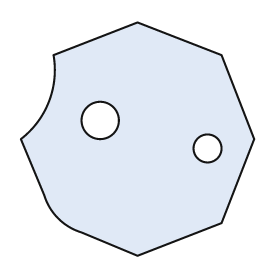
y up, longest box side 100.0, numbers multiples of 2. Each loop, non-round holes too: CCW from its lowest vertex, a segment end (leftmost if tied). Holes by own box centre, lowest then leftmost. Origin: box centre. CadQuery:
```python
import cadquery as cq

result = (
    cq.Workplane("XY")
    .moveTo(0.0, -50.0)
    .lineTo(36.0, -36.0)
    .lineTo(50.0, 0.0)
    .lineTo(36.0, 36.0)
    .lineTo(0.0, 50.0)
    .lineTo(-36.0, 36.0)
    .threePointArc((-38.0, 16.0), (-50.0, 0.0))
    .lineTo(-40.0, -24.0)
    .threePointArc((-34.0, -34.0), (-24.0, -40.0))
    .close()
    .moveTo(30.0, -4.0)
    .circle(6.0)
    .moveTo(-16.0, 8.0)
    .circle(8.0)
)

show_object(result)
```